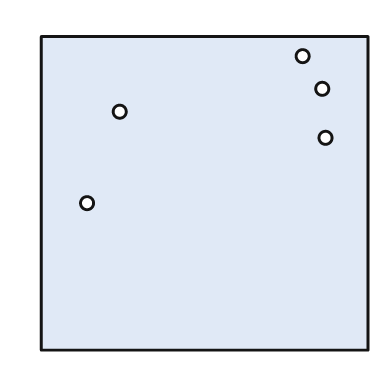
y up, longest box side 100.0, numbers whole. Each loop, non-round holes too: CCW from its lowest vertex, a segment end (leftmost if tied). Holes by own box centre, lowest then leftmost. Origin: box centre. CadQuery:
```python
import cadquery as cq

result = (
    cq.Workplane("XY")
    .moveTo(-50.0, -48.0)
    .lineTo(50.0, -48.0)
    .lineTo(50.0, 48.0)
    .lineTo(-50.0, 48.0)
    .close()
    .moveTo(-36.0, -3.0)
    .circle(2.0)
    .moveTo(37.0, 17.0)
    .circle(2.0)
    .moveTo(-26.0, 25.0)
    .circle(2.0)
    .moveTo(36.0, 32.0)
    .circle(2.0)
    .moveTo(30.0, 42.0)
    .circle(2.0)
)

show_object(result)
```